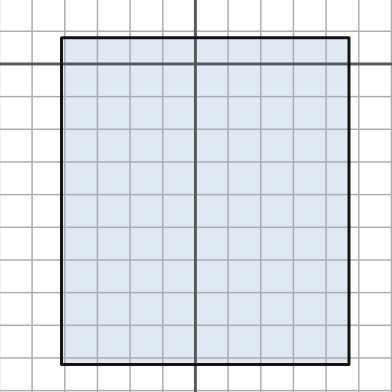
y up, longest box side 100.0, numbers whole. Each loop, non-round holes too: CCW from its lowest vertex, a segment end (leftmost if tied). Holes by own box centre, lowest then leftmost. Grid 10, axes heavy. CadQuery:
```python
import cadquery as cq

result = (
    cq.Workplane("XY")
    .moveTo(-41.0, -92.0)
    .lineTo(47.0, -92.0)
    .lineTo(47.0, 8.0)
    .lineTo(-41.0, 8.0)
    .close()
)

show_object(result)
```